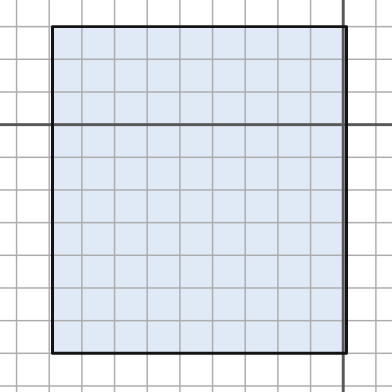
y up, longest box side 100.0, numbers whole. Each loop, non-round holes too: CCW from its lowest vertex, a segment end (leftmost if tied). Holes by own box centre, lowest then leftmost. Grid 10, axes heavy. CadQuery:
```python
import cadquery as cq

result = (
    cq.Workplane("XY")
    .moveTo(-89.0, -70.0)
    .lineTo(1.0, -70.0)
    .lineTo(1.0, 30.0)
    .lineTo(-89.0, 30.0)
    .close()
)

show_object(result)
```